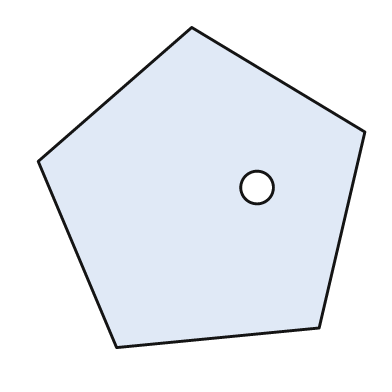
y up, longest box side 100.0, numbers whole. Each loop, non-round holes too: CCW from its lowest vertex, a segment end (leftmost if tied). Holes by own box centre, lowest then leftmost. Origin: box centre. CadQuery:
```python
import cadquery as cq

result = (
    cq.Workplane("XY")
    .moveTo(-26.0, -49.0)
    .lineTo(36.0, -43.0)
    .lineTo(50.0, 17.0)
    .lineTo(-3.0, 49.0)
    .lineTo(-50.0, 8.0)
    .close()
    .moveTo(17.0, 0.0)
    .circle(5.0)
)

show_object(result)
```